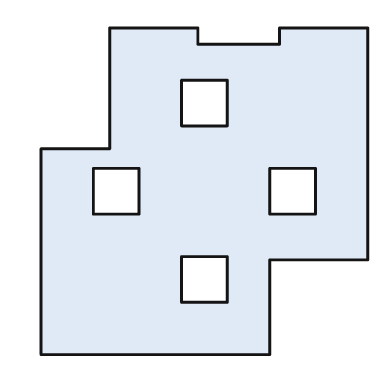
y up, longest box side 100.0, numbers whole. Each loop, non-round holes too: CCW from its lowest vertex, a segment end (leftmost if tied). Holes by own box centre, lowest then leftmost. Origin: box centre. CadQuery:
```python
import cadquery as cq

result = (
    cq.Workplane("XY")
    .moveTo(-50.0, -50.0)
    .lineTo(20.0, -50.0)
    .lineTo(20.0, -21.0)
    .lineTo(50.0, -21.0)
    .lineTo(50.0, 50.0)
    .lineTo(23.0, 50.0)
    .lineTo(23.0, 45.0)
    .lineTo(-2.0, 45.0)
    .lineTo(-2.0, 50.0)
    .lineTo(-29.0, 50.0)
    .lineTo(-29.0, 13.0)
    .lineTo(-50.0, 13.0)
    .close()
    .moveTo(-7.0, -34.0)
    .lineTo(7.0, -34.0)
    .lineTo(7.0, -20.0)
    .lineTo(-7.0, -20.0)
    .close()
    .moveTo(-34.0, -7.0)
    .lineTo(-20.0, -7.0)
    .lineTo(-20.0, 7.0)
    .lineTo(-34.0, 7.0)
    .close()
    .moveTo(20.0, -7.0)
    .lineTo(34.0, -7.0)
    .lineTo(34.0, 7.0)
    .lineTo(20.0, 7.0)
    .close()
    .moveTo(-7.0, 20.0)
    .lineTo(7.0, 20.0)
    .lineTo(7.0, 34.0)
    .lineTo(-7.0, 34.0)
    .close()
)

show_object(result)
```